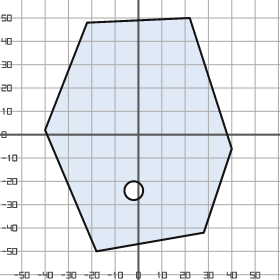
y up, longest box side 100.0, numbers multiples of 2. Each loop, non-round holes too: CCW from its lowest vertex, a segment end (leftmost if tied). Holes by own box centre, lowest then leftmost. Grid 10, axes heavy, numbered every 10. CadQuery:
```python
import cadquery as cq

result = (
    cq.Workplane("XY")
    .moveTo(-18.0, -50.0)
    .lineTo(28.0, -42.0)
    .lineTo(40.0, -6.0)
    .lineTo(22.0, 50.0)
    .lineTo(-22.0, 48.0)
    .lineTo(-40.0, 2.0)
    .close()
    .moveTo(-2.0, -24.0)
    .circle(4.0)
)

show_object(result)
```